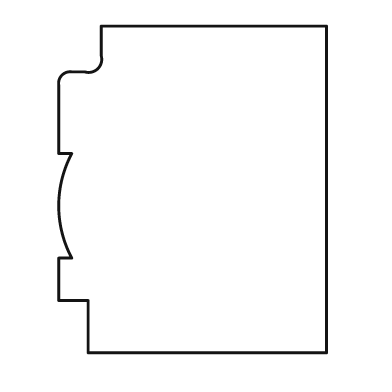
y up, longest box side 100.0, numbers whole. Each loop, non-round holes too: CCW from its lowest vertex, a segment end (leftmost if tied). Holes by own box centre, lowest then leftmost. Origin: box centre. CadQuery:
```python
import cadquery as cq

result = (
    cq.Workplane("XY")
    .moveTo(-32.0, -50.0)
    .lineTo(41.0, -50.0)
    .lineTo(41.0, 50.0)
    .lineTo(-28.0, 50.0)
    .lineTo(-28.0, 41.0)
    .threePointArc((-29.0, 37.0), (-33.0, 36.0))
    .lineTo(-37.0, 36.0)
    .threePointArc((-40.0, 35.0), (-41.0, 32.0))
    .lineTo(-41.0, 11.0)
    .lineTo(-37.0, 11.0)
    .threePointArc((-41.0, -5.0), (-37.0, -21.0))
    .lineTo(-41.0, -21.0)
    .lineTo(-41.0, -34.0)
    .lineTo(-32.0, -34.0)
    .close()
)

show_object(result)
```